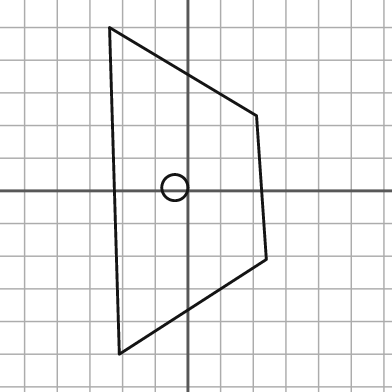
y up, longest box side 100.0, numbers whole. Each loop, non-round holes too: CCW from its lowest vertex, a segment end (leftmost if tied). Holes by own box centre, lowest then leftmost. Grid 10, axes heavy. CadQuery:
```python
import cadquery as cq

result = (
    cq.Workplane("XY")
    .moveTo(-21.0, -50.0)
    .lineTo(24.0, -21.0)
    .lineTo(21.0, 23.0)
    .lineTo(-24.0, 50.0)
    .close()
    .moveTo(-4.0, 1.0)
    .circle(4.0)
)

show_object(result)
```